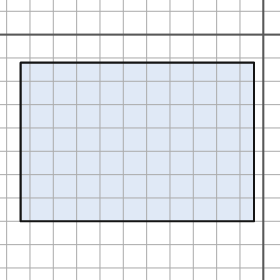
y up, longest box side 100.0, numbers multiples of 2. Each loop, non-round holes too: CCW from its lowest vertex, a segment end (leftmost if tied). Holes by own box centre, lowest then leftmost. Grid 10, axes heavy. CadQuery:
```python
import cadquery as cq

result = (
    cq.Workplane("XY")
    .moveTo(-104.0, -80.0)
    .lineTo(-4.0, -80.0)
    .lineTo(-4.0, -12.0)
    .lineTo(-104.0, -12.0)
    .close()
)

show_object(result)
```